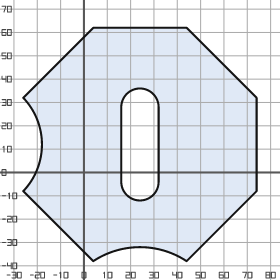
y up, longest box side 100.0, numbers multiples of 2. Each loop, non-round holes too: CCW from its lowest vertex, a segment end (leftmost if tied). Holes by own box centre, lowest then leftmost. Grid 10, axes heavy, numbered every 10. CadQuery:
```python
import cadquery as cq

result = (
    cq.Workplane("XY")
    .moveTo(4.0, -38.0)
    .threePointArc((24.0, -32.0), (44.0, -38.0))
    .lineTo(74.0, -8.0)
    .lineTo(74.0, 32.0)
    .lineTo(44.0, 62.0)
    .lineTo(4.0, 62.0)
    .lineTo(-26.0, 32.0)
    .threePointArc((-18.0, 12.0), (-26.0, -8.0))
    .close()
    .moveTo(16.0, -4.0)
    .threePointArc((24.0, -12.0), (32.0, -4.0))
    .lineTo(32.0, 28.0)
    .threePointArc((24.0, 36.0), (16.0, 28.0))
    .close()
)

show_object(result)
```